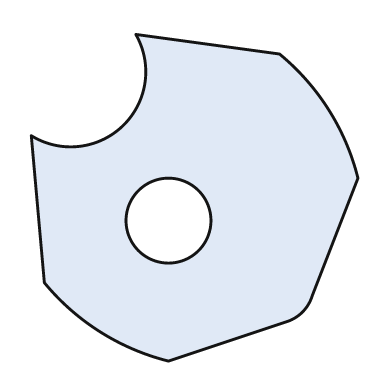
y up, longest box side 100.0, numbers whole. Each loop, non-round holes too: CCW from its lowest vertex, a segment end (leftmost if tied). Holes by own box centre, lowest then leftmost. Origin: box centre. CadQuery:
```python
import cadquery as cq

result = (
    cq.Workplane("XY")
    .moveTo(-8.0, -50.0)
    .lineTo(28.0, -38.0)
    .threePointArc((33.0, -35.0), (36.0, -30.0))
    .lineTo(50.0, 6.0)
    .threePointArc((41.0, 27.0), (26.0, 44.0))
    .lineTo(-18.0, 50.0)
    .threePointArc((-22.0, 22.0), (-50.0, 19.0))
    .lineTo(-46.0, -26.0)
    .threePointArc((-29.0, -41.0), (-8.0, -50.0))
    .close()
    .moveTo(-8.0, -7.0)
    .circle(13.0)
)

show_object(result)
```